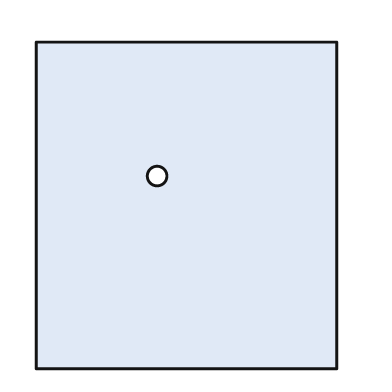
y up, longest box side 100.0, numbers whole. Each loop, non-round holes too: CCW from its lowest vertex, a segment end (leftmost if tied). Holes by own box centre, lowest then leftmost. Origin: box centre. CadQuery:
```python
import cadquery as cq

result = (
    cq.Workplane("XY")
    .moveTo(-46.0, -50.0)
    .lineTo(46.0, -50.0)
    .lineTo(46.0, 50.0)
    .lineTo(-46.0, 50.0)
    .close()
    .moveTo(-9.0, 9.0)
    .circle(3.0)
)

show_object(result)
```